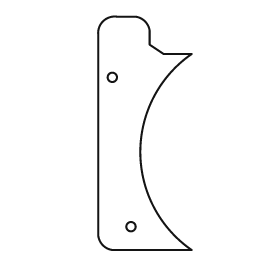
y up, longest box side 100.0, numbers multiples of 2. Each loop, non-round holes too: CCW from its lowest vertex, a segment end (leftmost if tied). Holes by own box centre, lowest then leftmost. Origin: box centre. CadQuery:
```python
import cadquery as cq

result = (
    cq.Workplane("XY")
    .moveTo(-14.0, -50.0)
    .lineTo(20.0, -50.0)
    .threePointArc((-2.0, -8.0), (20.0, 34.0))
    .lineTo(8.0, 34.0)
    .lineTo(2.0, 38.0)
    .lineTo(2.0, 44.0)
    .threePointArc((0.0, 48.0), (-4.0, 50.0))
    .lineTo(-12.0, 50.0)
    .threePointArc((-18.0, 48.0), (-20.0, 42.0))
    .lineTo(-20.0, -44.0)
    .threePointArc((-18.0, -48.0), (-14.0, -50.0))
    .close()
    .moveTo(-6.0, -40.0)
    .circle(2.0)
    .moveTo(-14.0, 24.0)
    .circle(2.0)
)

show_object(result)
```